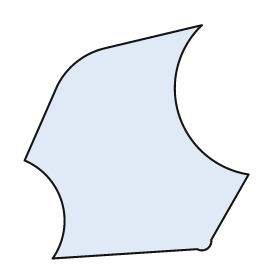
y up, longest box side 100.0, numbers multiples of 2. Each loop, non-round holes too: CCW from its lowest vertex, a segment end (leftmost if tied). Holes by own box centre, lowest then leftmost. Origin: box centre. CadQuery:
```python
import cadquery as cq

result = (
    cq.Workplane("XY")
    .moveTo(-36.0, -50.0)
    .lineTo(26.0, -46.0)
    .threePointArc((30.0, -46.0), (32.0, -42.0))
    .lineTo(48.0, -14.0)
    .threePointArc((18.0, 12.0), (28.0, 50.0))
    .lineTo(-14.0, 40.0)
    .threePointArc((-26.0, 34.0), (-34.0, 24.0))
    .lineTo(-48.0, -8.0)
    .threePointArc((-32.0, -26.0), (-36.0, -50.0))
    .close()
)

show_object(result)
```